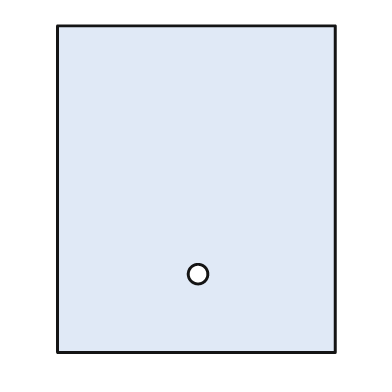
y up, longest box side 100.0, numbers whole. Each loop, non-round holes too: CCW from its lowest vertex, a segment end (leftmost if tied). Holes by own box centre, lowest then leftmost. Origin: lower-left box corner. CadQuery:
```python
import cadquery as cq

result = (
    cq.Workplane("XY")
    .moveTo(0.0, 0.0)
    .lineTo(85.0, 0.0)
    .lineTo(85.0, 100.0)
    .lineTo(0.0, 100.0)
    .close()
    .moveTo(43.0, 24.0)
    .circle(3.0)
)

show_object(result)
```